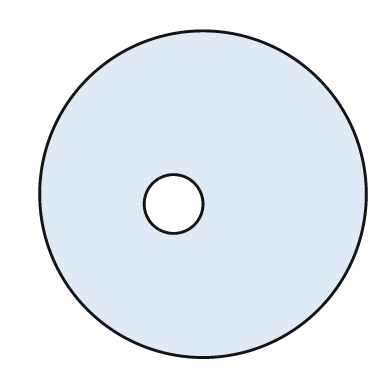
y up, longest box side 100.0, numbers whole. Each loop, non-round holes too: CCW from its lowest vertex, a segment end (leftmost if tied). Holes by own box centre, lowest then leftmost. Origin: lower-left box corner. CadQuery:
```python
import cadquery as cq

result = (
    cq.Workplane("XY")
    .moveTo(50.0, 50.0)
    .circle(50.0)
    .moveTo(41.0, 47.0)
    .circle(9.0)
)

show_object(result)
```